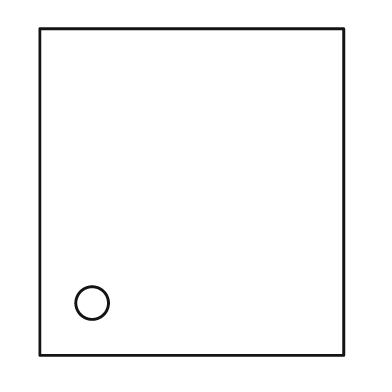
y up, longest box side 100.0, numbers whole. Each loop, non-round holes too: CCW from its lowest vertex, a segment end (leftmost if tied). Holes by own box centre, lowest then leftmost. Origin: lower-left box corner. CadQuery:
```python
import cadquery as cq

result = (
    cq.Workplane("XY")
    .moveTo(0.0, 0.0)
    .lineTo(93.0, 0.0)
    .lineTo(93.0, 100.0)
    .lineTo(0.0, 100.0)
    .close()
    .moveTo(16.0, 16.0)
    .circle(5.0)
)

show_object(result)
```